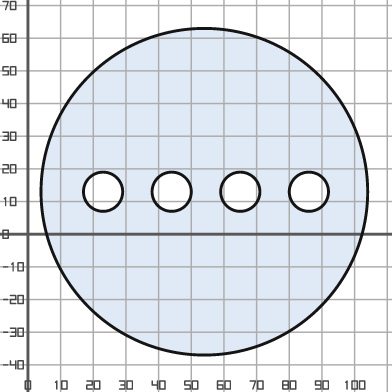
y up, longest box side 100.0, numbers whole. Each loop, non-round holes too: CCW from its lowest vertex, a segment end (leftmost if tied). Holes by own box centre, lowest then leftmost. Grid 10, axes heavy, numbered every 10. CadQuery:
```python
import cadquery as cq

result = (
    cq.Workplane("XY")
    .moveTo(54.0, 13.0)
    .circle(50.0)
    .moveTo(23.0, 13.0)
    .circle(6.0)
    .moveTo(44.0, 13.0)
    .circle(6.0)
    .moveTo(65.0, 13.0)
    .circle(6.0)
    .moveTo(86.0, 13.0)
    .circle(6.0)
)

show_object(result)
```